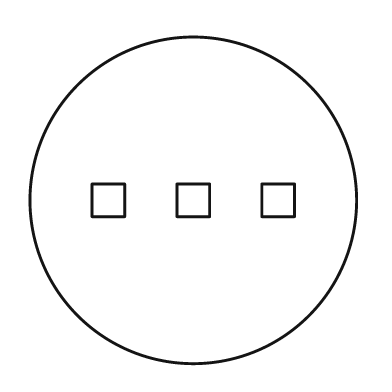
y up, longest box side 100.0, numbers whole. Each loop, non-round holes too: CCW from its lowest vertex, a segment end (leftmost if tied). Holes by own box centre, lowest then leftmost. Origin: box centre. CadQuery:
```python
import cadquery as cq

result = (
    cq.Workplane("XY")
    .moveTo(0.0, 0.0)
    .circle(50.0)
    .moveTo(-31.0, -5.0)
    .lineTo(-21.0, -5.0)
    .lineTo(-21.0, 5.0)
    .lineTo(-31.0, 5.0)
    .close()
    .moveTo(-5.0, -5.0)
    .lineTo(5.0, -5.0)
    .lineTo(5.0, 5.0)
    .lineTo(-5.0, 5.0)
    .close()
    .moveTo(21.0, -5.0)
    .lineTo(31.0, -5.0)
    .lineTo(31.0, 5.0)
    .lineTo(21.0, 5.0)
    .close()
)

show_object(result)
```